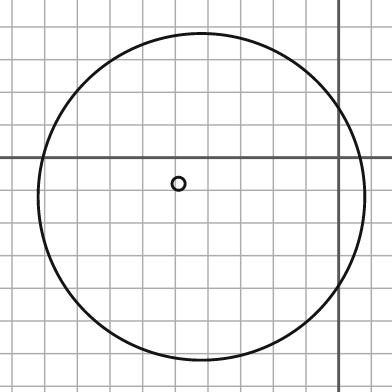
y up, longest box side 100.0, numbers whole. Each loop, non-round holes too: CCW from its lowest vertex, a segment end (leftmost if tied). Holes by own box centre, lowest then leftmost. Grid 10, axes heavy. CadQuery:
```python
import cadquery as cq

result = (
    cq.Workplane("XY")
    .moveTo(-42.0, -12.0)
    .circle(50.0)
    .moveTo(-49.0, -8.0)
    .circle(2.0)
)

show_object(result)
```